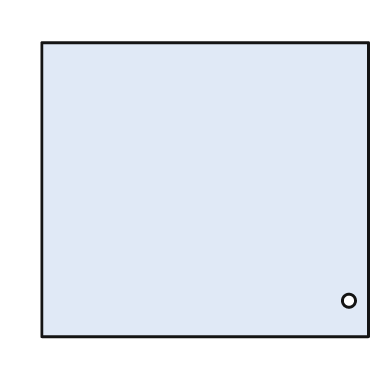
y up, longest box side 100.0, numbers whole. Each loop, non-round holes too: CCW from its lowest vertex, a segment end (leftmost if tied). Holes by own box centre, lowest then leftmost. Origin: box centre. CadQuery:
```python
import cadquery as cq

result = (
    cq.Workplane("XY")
    .moveTo(-50.0, -45.0)
    .lineTo(50.0, -45.0)
    .lineTo(50.0, 45.0)
    .lineTo(-50.0, 45.0)
    .close()
    .moveTo(44.0, -34.0)
    .circle(2.0)
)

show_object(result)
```